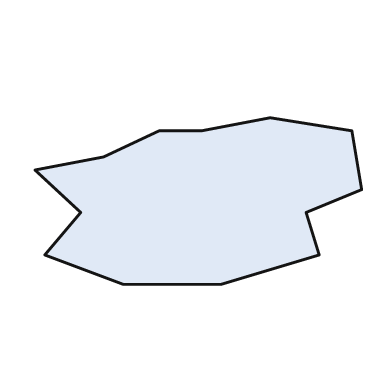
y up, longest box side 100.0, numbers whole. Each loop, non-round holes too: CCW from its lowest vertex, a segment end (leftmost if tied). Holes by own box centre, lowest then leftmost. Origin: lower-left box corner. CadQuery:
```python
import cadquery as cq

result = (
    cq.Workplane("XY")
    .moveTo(27.0, 0.0)
    .lineTo(57.0, 0.0)
    .lineTo(87.0, 9.0)
    .lineTo(83.0, 22.0)
    .lineTo(100.0, 29.0)
    .lineTo(97.0, 47.0)
    .lineTo(72.0, 51.0)
    .lineTo(51.0, 47.0)
    .lineTo(38.0, 47.0)
    .lineTo(21.0, 39.0)
    .lineTo(0.0, 35.0)
    .lineTo(14.0, 22.0)
    .lineTo(3.0, 9.0)
    .close()
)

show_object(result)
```